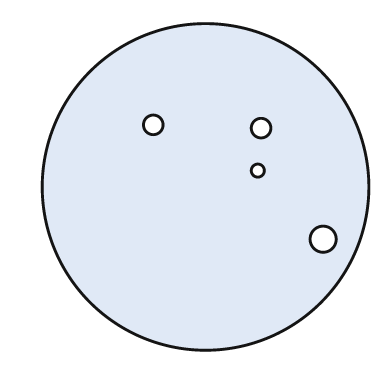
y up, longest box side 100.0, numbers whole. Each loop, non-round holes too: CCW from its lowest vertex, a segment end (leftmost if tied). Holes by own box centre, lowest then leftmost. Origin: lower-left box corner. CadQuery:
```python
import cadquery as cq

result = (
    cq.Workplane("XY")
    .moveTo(50.0, 50.0)
    .circle(50.0)
    .moveTo(86.0, 34.0)
    .circle(4.0)
    .moveTo(66.0, 55.0)
    .circle(2.0)
    .moveTo(67.0, 68.0)
    .circle(3.0)
    .moveTo(34.0, 69.0)
    .circle(3.0)
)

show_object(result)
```